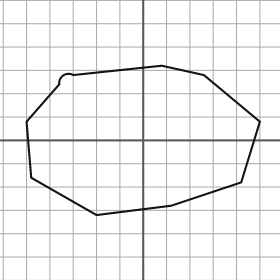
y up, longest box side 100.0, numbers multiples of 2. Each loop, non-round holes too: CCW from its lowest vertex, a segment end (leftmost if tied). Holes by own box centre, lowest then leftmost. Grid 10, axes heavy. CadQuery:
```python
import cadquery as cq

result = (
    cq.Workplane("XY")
    .moveTo(-20.0, -32.0)
    .lineTo(12.0, -28.0)
    .lineTo(42.0, -18.0)
    .lineTo(50.0, 8.0)
    .lineTo(26.0, 28.0)
    .lineTo(8.0, 32.0)
    .lineTo(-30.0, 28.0)
    .threePointArc((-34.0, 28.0), (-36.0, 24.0))
    .lineTo(-50.0, 8.0)
    .lineTo(-48.0, -16.0)
    .close()
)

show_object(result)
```